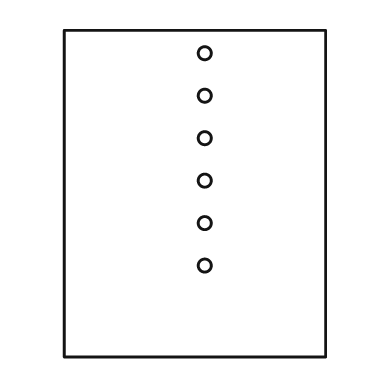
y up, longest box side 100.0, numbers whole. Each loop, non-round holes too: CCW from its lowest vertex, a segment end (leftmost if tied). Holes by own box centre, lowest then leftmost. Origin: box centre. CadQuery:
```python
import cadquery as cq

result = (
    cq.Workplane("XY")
    .moveTo(-40.0, -50.0)
    .lineTo(40.0, -50.0)
    .lineTo(40.0, 50.0)
    .lineTo(-40.0, 50.0)
    .close()
    .moveTo(3.0, -22.0)
    .circle(2.0)
    .moveTo(3.0, -9.0)
    .circle(2.0)
    .moveTo(3.0, 4.0)
    .circle(2.0)
    .moveTo(3.0, 17.0)
    .circle(2.0)
    .moveTo(3.0, 30.0)
    .circle(2.0)
    .moveTo(3.0, 43.0)
    .circle(2.0)
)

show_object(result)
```